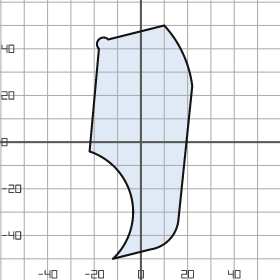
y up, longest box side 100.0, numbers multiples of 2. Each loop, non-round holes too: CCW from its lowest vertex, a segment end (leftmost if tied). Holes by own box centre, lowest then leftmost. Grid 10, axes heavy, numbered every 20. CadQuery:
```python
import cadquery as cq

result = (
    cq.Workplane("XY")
    .moveTo(-12.0, -50.0)
    .lineTo(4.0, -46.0)
    .threePointArc((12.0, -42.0), (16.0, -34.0))
    .lineTo(22.0, 24.0)
    .threePointArc((18.0, 38.0), (10.0, 50.0))
    .lineTo(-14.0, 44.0)
    .threePointArc((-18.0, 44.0), (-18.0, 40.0))
    .lineTo(-22.0, -4.0)
    .threePointArc((-4.0, -24.0), (-12.0, -50.0))
    .close()
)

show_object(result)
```